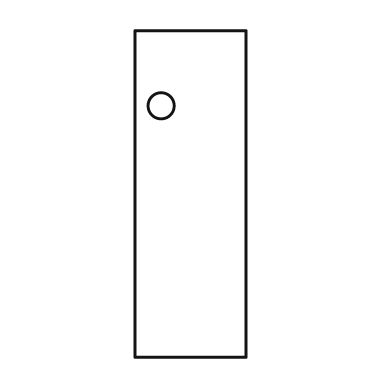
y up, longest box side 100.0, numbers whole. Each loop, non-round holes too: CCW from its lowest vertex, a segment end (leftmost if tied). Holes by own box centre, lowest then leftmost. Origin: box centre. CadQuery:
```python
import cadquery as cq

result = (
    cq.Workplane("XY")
    .moveTo(-17.0, -50.0)
    .lineTo(17.0, -50.0)
    .lineTo(17.0, 50.0)
    .lineTo(-17.0, 50.0)
    .close()
    .moveTo(-9.0, 27.0)
    .circle(4.0)
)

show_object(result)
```